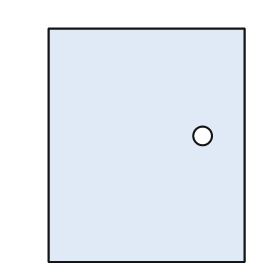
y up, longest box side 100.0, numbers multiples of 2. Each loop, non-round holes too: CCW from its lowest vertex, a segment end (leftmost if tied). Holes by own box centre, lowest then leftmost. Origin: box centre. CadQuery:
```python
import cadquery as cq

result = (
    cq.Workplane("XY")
    .moveTo(-42.0, -50.0)
    .lineTo(42.0, -50.0)
    .lineTo(42.0, 50.0)
    .lineTo(-42.0, 50.0)
    .close()
    .moveTo(24.0, 4.0)
    .circle(4.0)
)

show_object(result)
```